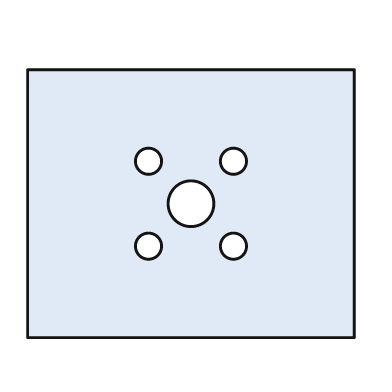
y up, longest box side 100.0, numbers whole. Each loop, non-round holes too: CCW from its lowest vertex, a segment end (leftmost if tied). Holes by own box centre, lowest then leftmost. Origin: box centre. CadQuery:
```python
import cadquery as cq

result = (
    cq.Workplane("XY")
    .moveTo(-50.0, -41.0)
    .lineTo(50.0, -41.0)
    .lineTo(50.0, 41.0)
    .lineTo(-50.0, 41.0)
    .close()
    .moveTo(-13.0, -13.0)
    .circle(4.0)
    .moveTo(13.0, -13.0)
    .circle(4.0)
    .moveTo(0.0, 0.0)
    .circle(7.0)
    .moveTo(-13.0, 13.0)
    .circle(4.0)
    .moveTo(13.0, 13.0)
    .circle(4.0)
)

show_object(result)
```